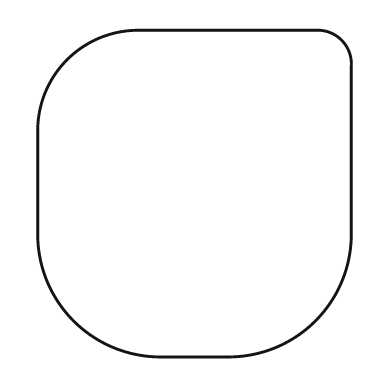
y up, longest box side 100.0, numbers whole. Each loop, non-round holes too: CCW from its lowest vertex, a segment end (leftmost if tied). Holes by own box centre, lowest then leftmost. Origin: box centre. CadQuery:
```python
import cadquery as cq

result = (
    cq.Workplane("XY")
    .moveTo(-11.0, -50.0)
    .lineTo(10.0, -50.0)
    .threePointArc((37.0, -39.0), (48.0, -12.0))
    .lineTo(48.0, 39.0)
    .threePointArc((45.0, 47.0), (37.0, 50.0))
    .lineTo(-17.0, 50.0)
    .threePointArc((-39.0, 41.0), (-48.0, 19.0))
    .lineTo(-48.0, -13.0)
    .threePointArc((-37.0, -39.0), (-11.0, -50.0))
    .close()
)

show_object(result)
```